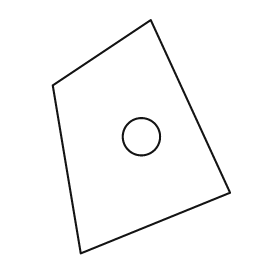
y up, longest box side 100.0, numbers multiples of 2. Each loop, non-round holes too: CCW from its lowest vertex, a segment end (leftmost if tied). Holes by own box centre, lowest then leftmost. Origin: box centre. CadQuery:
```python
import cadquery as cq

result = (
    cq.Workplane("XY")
    .moveTo(-26.0, -50.0)
    .lineTo(38.0, -24.0)
    .lineTo(4.0, 50.0)
    .lineTo(-38.0, 22.0)
    .close()
    .moveTo(0.0, 0.0)
    .circle(8.0)
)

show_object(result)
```